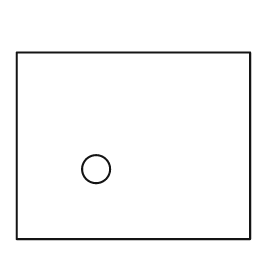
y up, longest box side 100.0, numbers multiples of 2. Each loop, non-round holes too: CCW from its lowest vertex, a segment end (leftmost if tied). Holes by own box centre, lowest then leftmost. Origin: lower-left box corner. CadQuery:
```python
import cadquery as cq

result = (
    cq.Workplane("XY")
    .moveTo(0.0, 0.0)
    .lineTo(100.0, 0.0)
    .lineTo(100.0, 80.0)
    .lineTo(0.0, 80.0)
    .close()
    .moveTo(34.0, 30.0)
    .circle(6.0)
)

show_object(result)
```